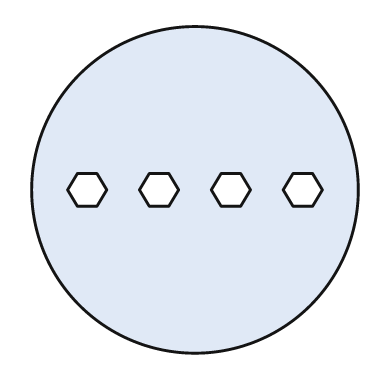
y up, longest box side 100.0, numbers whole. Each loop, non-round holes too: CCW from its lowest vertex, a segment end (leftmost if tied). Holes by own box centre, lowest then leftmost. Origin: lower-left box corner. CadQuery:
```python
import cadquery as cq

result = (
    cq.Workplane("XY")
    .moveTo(50.0, 50.0)
    .circle(50.0)
    .moveTo(14.0, 45.0)
    .lineTo(20.0, 45.0)
    .lineTo(23.0, 50.0)
    .lineTo(20.0, 55.0)
    .lineTo(14.0, 55.0)
    .lineTo(11.0, 50.0)
    .close()
    .moveTo(36.0, 45.0)
    .lineTo(42.0, 45.0)
    .lineTo(45.0, 50.0)
    .lineTo(42.0, 55.0)
    .lineTo(36.0, 55.0)
    .lineTo(33.0, 50.0)
    .close()
    .moveTo(58.0, 45.0)
    .lineTo(64.0, 45.0)
    .lineTo(67.0, 50.0)
    .lineTo(64.0, 55.0)
    .lineTo(58.0, 55.0)
    .lineTo(55.0, 50.0)
    .close()
    .moveTo(80.0, 45.0)
    .lineTo(86.0, 45.0)
    .lineTo(89.0, 50.0)
    .lineTo(86.0, 55.0)
    .lineTo(80.0, 55.0)
    .lineTo(77.0, 50.0)
    .close()
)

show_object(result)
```